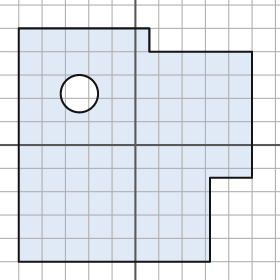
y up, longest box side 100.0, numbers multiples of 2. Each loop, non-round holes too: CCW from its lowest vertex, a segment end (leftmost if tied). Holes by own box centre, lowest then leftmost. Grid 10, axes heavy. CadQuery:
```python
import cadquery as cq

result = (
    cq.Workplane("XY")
    .moveTo(-50.0, -50.0)
    .lineTo(32.0, -50.0)
    .lineTo(32.0, -14.0)
    .lineTo(50.0, -14.0)
    .lineTo(50.0, 40.0)
    .lineTo(6.0, 40.0)
    .lineTo(6.0, 50.0)
    .lineTo(-50.0, 50.0)
    .close()
    .moveTo(-24.0, 22.0)
    .circle(8.0)
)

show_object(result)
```